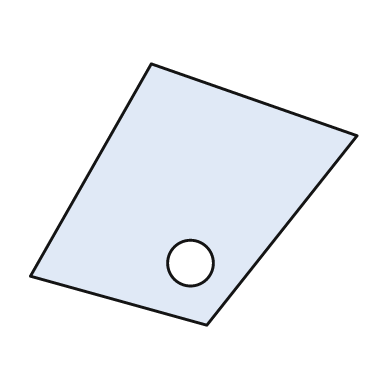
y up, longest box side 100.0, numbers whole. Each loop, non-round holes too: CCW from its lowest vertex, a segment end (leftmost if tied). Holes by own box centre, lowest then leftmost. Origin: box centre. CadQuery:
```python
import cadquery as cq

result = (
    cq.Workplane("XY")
    .moveTo(4.0, -40.0)
    .lineTo(50.0, 18.0)
    .lineTo(-13.0, 40.0)
    .lineTo(-50.0, -25.0)
    .close()
    .moveTo(-1.0, -21.0)
    .circle(7.0)
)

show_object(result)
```